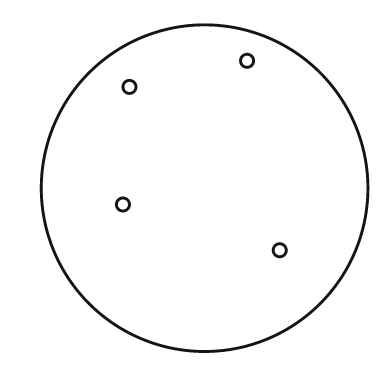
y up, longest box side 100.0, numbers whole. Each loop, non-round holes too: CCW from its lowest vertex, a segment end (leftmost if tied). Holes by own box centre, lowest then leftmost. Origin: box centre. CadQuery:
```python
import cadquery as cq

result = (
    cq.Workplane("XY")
    .moveTo(0.0, 0.0)
    .circle(50.0)
    .moveTo(23.0, -19.0)
    .circle(2.0)
    .moveTo(-25.0, -5.0)
    .circle(2.0)
    .moveTo(-23.0, 31.0)
    .circle(2.0)
    .moveTo(13.0, 39.0)
    .circle(2.0)
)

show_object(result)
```